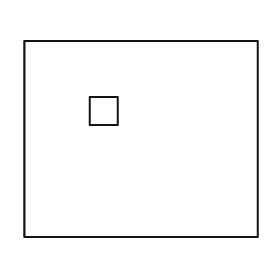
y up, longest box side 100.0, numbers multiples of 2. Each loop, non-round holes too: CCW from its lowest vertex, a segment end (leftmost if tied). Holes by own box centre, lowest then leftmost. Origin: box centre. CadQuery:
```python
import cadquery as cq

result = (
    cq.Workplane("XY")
    .moveTo(-50.0, -42.0)
    .lineTo(50.0, -42.0)
    .lineTo(50.0, 42.0)
    .lineTo(-50.0, 42.0)
    .close()
    .moveTo(-22.0, 6.0)
    .lineTo(-10.0, 6.0)
    .lineTo(-10.0, 18.0)
    .lineTo(-22.0, 18.0)
    .close()
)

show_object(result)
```